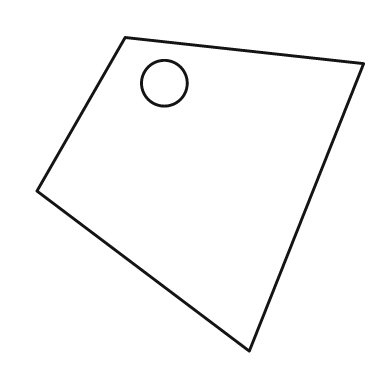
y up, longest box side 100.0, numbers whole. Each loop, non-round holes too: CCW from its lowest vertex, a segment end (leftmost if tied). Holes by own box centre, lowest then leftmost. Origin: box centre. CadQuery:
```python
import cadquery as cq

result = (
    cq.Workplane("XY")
    .moveTo(15.0, -48.0)
    .lineTo(50.0, 40.0)
    .lineTo(-23.0, 48.0)
    .lineTo(-50.0, 1.0)
    .close()
    .moveTo(-11.0, 34.0)
    .circle(7.0)
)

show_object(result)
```